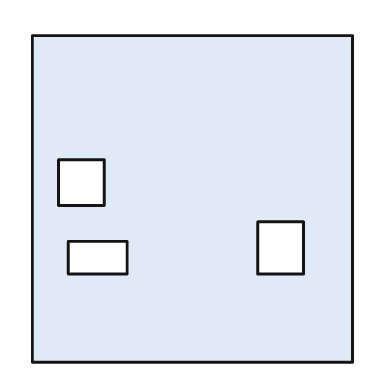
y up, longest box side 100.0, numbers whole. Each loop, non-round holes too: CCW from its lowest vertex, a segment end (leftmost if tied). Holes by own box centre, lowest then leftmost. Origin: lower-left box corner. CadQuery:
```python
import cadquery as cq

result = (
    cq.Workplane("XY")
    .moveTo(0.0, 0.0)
    .lineTo(98.0, 0.0)
    .lineTo(98.0, 100.0)
    .lineTo(0.0, 100.0)
    .close()
    .moveTo(11.0, 27.0)
    .lineTo(29.0, 27.0)
    .lineTo(29.0, 37.0)
    .lineTo(11.0, 37.0)
    .close()
    .moveTo(69.0, 27.0)
    .lineTo(83.0, 27.0)
    .lineTo(83.0, 43.0)
    .lineTo(69.0, 43.0)
    .close()
    .moveTo(8.0, 48.0)
    .lineTo(22.0, 48.0)
    .lineTo(22.0, 62.0)
    .lineTo(8.0, 62.0)
    .close()
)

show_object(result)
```